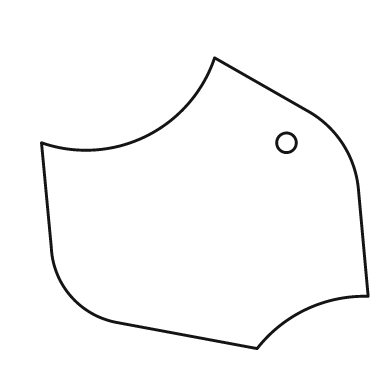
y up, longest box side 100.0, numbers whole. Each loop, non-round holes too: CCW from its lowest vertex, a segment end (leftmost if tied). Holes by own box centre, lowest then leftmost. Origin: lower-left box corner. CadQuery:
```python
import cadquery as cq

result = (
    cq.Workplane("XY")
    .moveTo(66.0, 0.0)
    .threePointArc((81.0, 12.0), (100.0, 16.0))
    .lineTo(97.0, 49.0)
    .threePointArc((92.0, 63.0), (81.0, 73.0))
    .lineTo(53.0, 89.0)
    .threePointArc((32.0, 65.0), (0.0, 63.0))
    .lineTo(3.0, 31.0)
    .threePointArc((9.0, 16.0), (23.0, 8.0))
    .close()
    .moveTo(75.0, 63.0)
    .circle(3.0)
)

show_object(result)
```